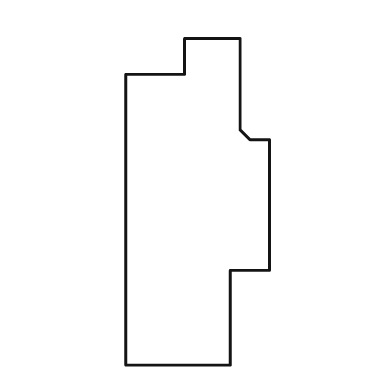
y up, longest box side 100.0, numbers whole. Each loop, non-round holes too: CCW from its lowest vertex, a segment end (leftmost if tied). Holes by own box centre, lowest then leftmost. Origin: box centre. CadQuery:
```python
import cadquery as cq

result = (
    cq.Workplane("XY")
    .moveTo(-22.0, -50.0)
    .lineTo(10.0, -50.0)
    .lineTo(10.0, -21.0)
    .lineTo(22.0, -21.0)
    .lineTo(22.0, 19.0)
    .lineTo(16.0, 19.0)
    .lineTo(13.0, 22.0)
    .lineTo(13.0, 50.0)
    .lineTo(-4.0, 50.0)
    .lineTo(-4.0, 39.0)
    .lineTo(-22.0, 39.0)
    .close()
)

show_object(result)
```